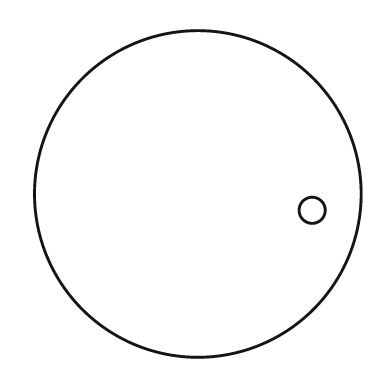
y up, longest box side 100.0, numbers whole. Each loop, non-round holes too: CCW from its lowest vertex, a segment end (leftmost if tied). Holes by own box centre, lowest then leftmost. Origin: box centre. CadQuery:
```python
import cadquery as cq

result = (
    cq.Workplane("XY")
    .moveTo(0.0, 0.0)
    .circle(50.0)
    .moveTo(35.0, -5.0)
    .circle(4.0)
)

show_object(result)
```